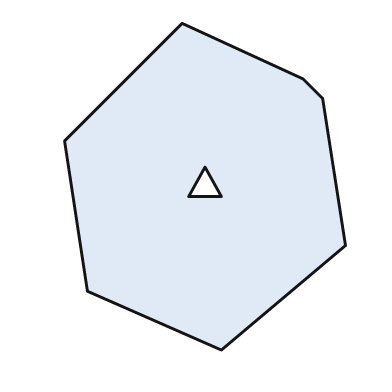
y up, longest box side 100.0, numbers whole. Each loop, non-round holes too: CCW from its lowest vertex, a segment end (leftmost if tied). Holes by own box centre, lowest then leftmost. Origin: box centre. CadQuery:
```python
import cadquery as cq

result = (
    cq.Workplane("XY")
    .moveTo(5.0, -50.0)
    .lineTo(43.0, -18.0)
    .lineTo(36.0, 27.0)
    .lineTo(30.0, 33.0)
    .lineTo(-7.0, 50.0)
    .lineTo(-43.0, 14.0)
    .lineTo(-36.0, -32.0)
    .close()
    .moveTo(-5.0, -3.0)
    .lineTo(5.0, -3.0)
    .lineTo(0.0, 6.0)
    .close()
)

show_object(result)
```